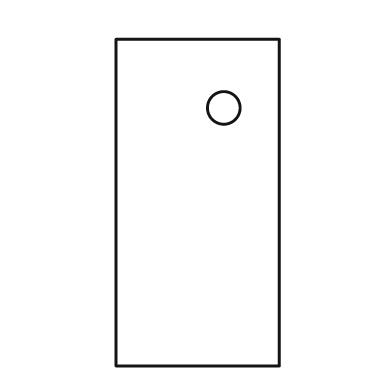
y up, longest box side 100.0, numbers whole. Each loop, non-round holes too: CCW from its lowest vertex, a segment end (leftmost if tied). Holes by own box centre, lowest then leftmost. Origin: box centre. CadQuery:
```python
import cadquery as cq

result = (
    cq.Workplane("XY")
    .moveTo(-25.0, -50.0)
    .lineTo(25.0, -50.0)
    .lineTo(25.0, 50.0)
    .lineTo(-25.0, 50.0)
    .close()
    .moveTo(8.0, 29.0)
    .circle(5.0)
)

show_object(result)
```